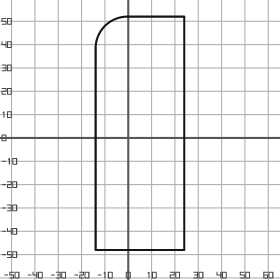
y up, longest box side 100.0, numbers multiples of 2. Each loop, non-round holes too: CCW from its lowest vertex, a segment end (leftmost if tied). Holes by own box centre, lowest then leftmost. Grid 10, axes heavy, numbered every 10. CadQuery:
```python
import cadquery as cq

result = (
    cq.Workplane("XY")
    .moveTo(-14.0, -48.0)
    .lineTo(24.0, -48.0)
    .lineTo(24.0, 52.0)
    .lineTo(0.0, 52.0)
    .threePointArc((-10.0, 48.0), (-14.0, 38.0))
    .close()
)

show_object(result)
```